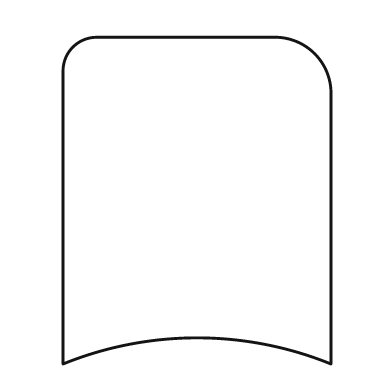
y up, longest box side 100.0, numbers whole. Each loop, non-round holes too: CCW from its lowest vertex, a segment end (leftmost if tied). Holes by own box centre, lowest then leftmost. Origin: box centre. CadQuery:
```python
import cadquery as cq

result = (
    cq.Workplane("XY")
    .moveTo(-41.0, -50.0)
    .threePointArc((0.0, -42.0), (41.0, -50.0))
    .lineTo(41.0, 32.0)
    .threePointArc((36.0, 45.0), (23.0, 50.0))
    .lineTo(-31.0, 50.0)
    .threePointArc((-38.0, 47.0), (-41.0, 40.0))
    .close()
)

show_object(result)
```